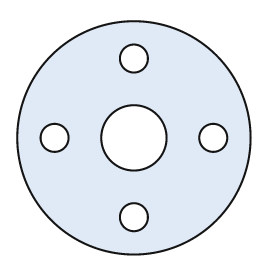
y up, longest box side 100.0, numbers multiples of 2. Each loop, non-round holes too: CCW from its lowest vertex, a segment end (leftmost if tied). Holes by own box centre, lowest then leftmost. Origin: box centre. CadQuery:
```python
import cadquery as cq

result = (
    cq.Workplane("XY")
    .moveTo(0.0, 0.0)
    .circle(50.0)
    .moveTo(0.0, -34.0)
    .circle(6.0)
    .moveTo(-34.0, 0.0)
    .circle(6.0)
    .moveTo(0.0, 0.0)
    .circle(14.0)
    .moveTo(34.0, 0.0)
    .circle(6.0)
    .moveTo(0.0, 34.0)
    .circle(6.0)
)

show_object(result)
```